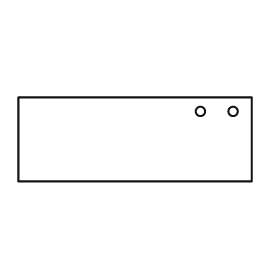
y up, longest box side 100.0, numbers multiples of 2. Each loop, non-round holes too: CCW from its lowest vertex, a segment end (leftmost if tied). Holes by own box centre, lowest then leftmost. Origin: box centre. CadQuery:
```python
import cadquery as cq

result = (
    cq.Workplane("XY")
    .moveTo(-50.0, -18.0)
    .lineTo(50.0, -18.0)
    .lineTo(50.0, 18.0)
    .lineTo(-50.0, 18.0)
    .close()
    .moveTo(28.0, 12.0)
    .circle(2.0)
    .moveTo(42.0, 12.0)
    .circle(2.0)
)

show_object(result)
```